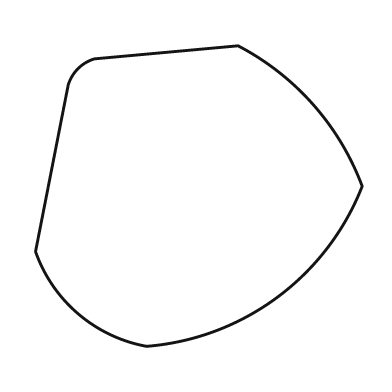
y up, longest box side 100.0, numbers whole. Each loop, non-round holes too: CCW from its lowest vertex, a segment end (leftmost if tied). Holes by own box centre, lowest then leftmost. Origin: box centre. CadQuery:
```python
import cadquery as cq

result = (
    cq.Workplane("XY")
    .moveTo(-16.0, -46.0)
    .threePointArc((24.0, -31.0), (50.0, 3.0))
    .threePointArc((35.0, 28.0), (12.0, 46.0))
    .lineTo(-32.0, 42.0)
    .threePointArc((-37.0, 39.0), (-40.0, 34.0))
    .lineTo(-50.0, -17.0)
    .threePointArc((-37.0, -36.0), (-16.0, -46.0))
    .close()
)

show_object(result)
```